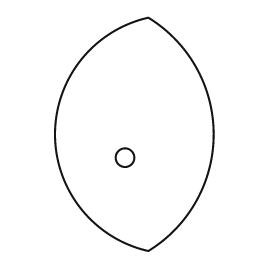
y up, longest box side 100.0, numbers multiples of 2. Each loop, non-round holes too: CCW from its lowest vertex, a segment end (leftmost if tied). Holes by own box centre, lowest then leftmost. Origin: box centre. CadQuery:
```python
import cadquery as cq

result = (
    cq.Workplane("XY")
    .moveTo(6.0, -50.0)
    .threePointArc((34.0, 0.0), (6.0, 50.0))
    .threePointArc((-34.0, 0.0), (6.0, -50.0))
    .close()
    .moveTo(-4.0, -10.0)
    .circle(4.0)
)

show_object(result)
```